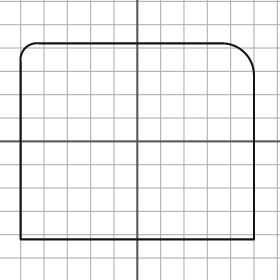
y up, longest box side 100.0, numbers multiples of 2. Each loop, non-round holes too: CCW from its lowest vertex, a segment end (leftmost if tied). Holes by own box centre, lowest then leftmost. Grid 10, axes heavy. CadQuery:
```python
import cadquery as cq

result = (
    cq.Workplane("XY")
    .moveTo(-50.0, -42.0)
    .lineTo(50.0, -42.0)
    .lineTo(50.0, 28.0)
    .threePointArc((46.0, 38.0), (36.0, 42.0))
    .lineTo(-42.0, 42.0)
    .threePointArc((-48.0, 40.0), (-50.0, 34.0))
    .close()
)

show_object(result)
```